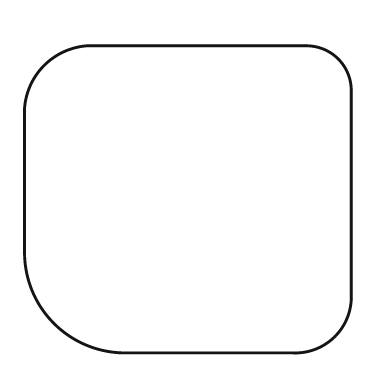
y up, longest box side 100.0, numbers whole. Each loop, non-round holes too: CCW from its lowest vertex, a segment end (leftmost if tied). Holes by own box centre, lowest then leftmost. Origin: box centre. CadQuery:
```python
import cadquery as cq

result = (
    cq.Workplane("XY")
    .moveTo(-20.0, -47.0)
    .lineTo(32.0, -47.0)
    .threePointArc((45.0, -42.0), (50.0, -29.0))
    .lineTo(50.0, 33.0)
    .threePointArc((46.0, 43.0), (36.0, 47.0))
    .lineTo(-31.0, 47.0)
    .threePointArc((-44.0, 41.0), (-50.0, 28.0))
    .lineTo(-50.0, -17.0)
    .threePointArc((-41.0, -38.0), (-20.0, -47.0))
    .close()
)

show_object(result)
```